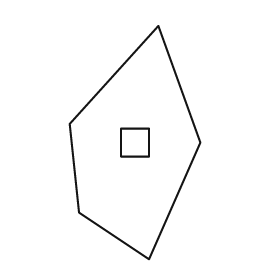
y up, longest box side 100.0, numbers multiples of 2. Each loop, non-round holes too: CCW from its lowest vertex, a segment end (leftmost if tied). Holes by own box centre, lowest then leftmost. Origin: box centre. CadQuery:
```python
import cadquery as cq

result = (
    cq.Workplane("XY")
    .moveTo(6.0, -50.0)
    .lineTo(28.0, 0.0)
    .lineTo(10.0, 50.0)
    .lineTo(-28.0, 8.0)
    .lineTo(-24.0, -30.0)
    .close()
    .moveTo(-6.0, -6.0)
    .lineTo(6.0, -6.0)
    .lineTo(6.0, 6.0)
    .lineTo(-6.0, 6.0)
    .close()
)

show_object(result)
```